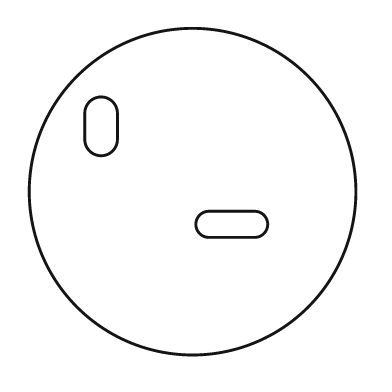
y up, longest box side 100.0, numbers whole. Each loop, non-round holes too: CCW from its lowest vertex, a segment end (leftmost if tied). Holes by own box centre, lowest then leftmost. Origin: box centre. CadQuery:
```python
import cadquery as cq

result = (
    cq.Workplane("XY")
    .moveTo(0.0, 0.0)
    .circle(50.0)
    .moveTo(5.0, -14.0)
    .lineTo(19.0, -14.0)
    .threePointArc((23.0, -10.0), (19.0, -6.0))
    .lineTo(5.0, -6.0)
    .threePointArc((1.0, -10.0), (5.0, -14.0))
    .close()
    .moveTo(-33.0, 16.0)
    .threePointArc((-28.0, 11.0), (-23.0, 16.0))
    .lineTo(-23.0, 24.0)
    .threePointArc((-28.0, 29.0), (-33.0, 24.0))
    .close()
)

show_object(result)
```